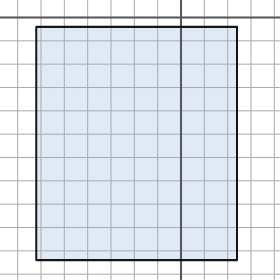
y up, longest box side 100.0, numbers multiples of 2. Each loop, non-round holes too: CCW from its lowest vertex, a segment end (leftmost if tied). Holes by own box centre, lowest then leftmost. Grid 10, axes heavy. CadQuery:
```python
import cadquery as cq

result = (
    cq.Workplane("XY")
    .moveTo(-62.0, -104.0)
    .lineTo(24.0, -104.0)
    .lineTo(24.0, -4.0)
    .lineTo(-62.0, -4.0)
    .close()
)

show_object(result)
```